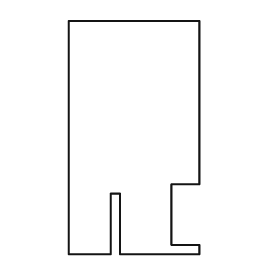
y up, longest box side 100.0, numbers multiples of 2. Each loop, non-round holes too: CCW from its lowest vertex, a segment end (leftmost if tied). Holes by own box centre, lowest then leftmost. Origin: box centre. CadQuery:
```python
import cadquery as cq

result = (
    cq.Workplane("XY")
    .moveTo(-28.0, -50.0)
    .lineTo(-10.0, -50.0)
    .lineTo(-10.0, -24.0)
    .lineTo(-6.0, -24.0)
    .lineTo(-6.0, -50.0)
    .lineTo(28.0, -50.0)
    .lineTo(28.0, -46.0)
    .lineTo(16.0, -46.0)
    .lineTo(16.0, -20.0)
    .lineTo(28.0, -20.0)
    .lineTo(28.0, 50.0)
    .lineTo(-28.0, 50.0)
    .close()
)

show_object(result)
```